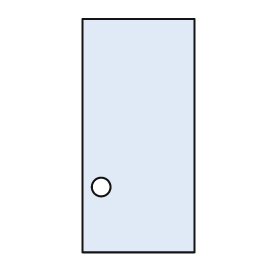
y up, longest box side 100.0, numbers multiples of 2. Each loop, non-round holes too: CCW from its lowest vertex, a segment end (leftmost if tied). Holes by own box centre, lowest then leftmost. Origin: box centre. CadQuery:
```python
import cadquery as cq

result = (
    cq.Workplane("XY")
    .moveTo(-24.0, -50.0)
    .lineTo(24.0, -50.0)
    .lineTo(24.0, 50.0)
    .lineTo(-24.0, 50.0)
    .close()
    .moveTo(-16.0, -22.0)
    .circle(4.0)
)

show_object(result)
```